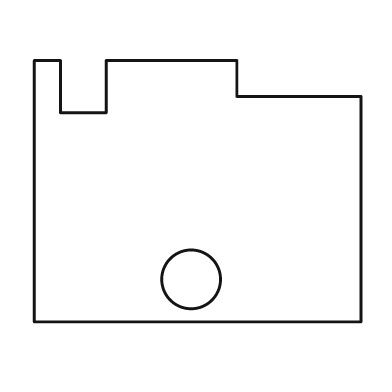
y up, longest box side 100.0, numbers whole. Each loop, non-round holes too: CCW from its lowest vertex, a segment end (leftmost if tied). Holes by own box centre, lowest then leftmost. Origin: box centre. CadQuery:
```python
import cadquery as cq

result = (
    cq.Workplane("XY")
    .moveTo(-50.0, -40.0)
    .lineTo(50.0, -40.0)
    .lineTo(50.0, 29.0)
    .lineTo(12.0, 29.0)
    .lineTo(12.0, 40.0)
    .lineTo(-28.0, 40.0)
    .lineTo(-28.0, 24.0)
    .lineTo(-42.0, 24.0)
    .lineTo(-42.0, 40.0)
    .lineTo(-50.0, 40.0)
    .close()
    .moveTo(-2.0, -27.0)
    .circle(9.0)
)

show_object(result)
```